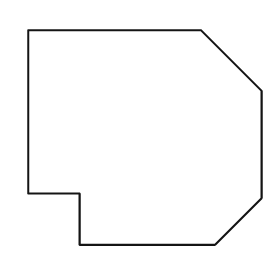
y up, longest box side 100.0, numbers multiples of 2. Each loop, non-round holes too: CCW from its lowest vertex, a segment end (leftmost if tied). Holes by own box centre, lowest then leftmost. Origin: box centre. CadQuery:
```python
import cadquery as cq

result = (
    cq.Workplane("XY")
    .moveTo(-28.0, -46.0)
    .lineTo(30.0, -46.0)
    .lineTo(50.0, -26.0)
    .lineTo(50.0, 20.0)
    .lineTo(24.0, 46.0)
    .lineTo(-50.0, 46.0)
    .lineTo(-50.0, -24.0)
    .lineTo(-28.0, -24.0)
    .close()
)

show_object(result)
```